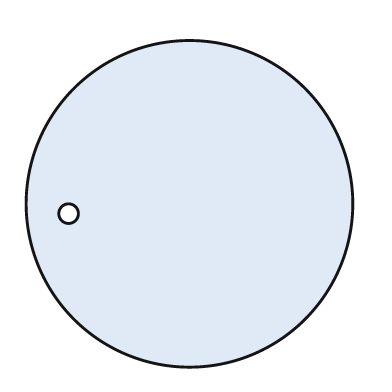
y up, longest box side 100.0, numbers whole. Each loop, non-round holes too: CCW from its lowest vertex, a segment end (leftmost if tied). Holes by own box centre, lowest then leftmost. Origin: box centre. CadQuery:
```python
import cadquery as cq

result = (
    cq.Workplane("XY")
    .moveTo(0.0, 0.0)
    .circle(50.0)
    .moveTo(-37.0, -3.0)
    .circle(3.0)
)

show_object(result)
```